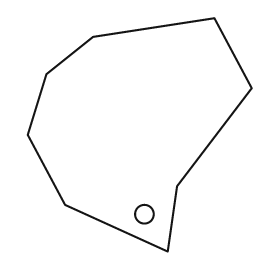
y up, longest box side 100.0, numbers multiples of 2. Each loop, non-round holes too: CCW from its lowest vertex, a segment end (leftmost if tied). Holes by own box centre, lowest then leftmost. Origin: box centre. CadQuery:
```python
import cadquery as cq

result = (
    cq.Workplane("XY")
    .moveTo(12.0, -50.0)
    .lineTo(16.0, -22.0)
    .lineTo(48.0, 20.0)
    .lineTo(32.0, 50.0)
    .lineTo(-20.0, 42.0)
    .lineTo(-40.0, 26.0)
    .lineTo(-48.0, 0.0)
    .lineTo(-32.0, -30.0)
    .close()
    .moveTo(2.0, -34.0)
    .circle(4.0)
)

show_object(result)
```